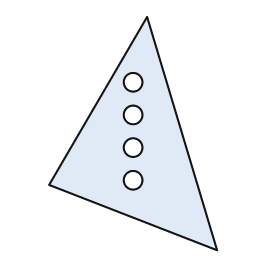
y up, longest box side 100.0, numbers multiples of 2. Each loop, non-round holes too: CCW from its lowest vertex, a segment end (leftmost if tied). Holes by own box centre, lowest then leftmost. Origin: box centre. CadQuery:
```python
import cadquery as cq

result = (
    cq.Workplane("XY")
    .moveTo(36.0, -50.0)
    .lineTo(6.0, 50.0)
    .lineTo(-36.0, -22.0)
    .close()
    .moveTo(0.0, -20.0)
    .circle(4.0)
    .moveTo(0.0, -6.0)
    .circle(4.0)
    .moveTo(0.0, 8.0)
    .circle(4.0)
    .moveTo(0.0, 22.0)
    .circle(4.0)
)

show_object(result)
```